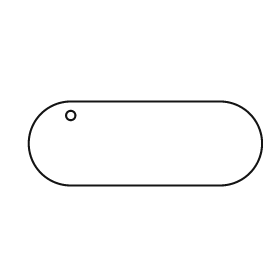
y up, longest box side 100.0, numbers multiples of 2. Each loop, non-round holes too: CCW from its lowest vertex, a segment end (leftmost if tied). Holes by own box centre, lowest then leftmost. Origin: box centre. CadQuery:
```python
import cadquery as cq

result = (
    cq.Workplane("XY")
    .moveTo(-32.0, -18.0)
    .lineTo(32.0, -18.0)
    .threePointArc((50.0, 0.0), (32.0, 18.0))
    .lineTo(-32.0, 18.0)
    .threePointArc((-50.0, 0.0), (-32.0, -18.0))
    .close()
    .moveTo(-32.0, 12.0)
    .circle(2.0)
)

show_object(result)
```